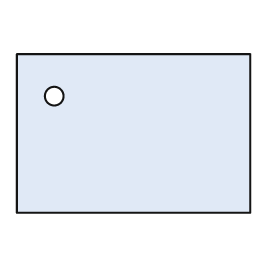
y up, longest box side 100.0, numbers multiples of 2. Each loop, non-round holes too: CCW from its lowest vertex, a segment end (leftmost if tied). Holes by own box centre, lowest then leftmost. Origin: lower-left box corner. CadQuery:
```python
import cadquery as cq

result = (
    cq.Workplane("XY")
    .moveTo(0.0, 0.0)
    .lineTo(100.0, 0.0)
    .lineTo(100.0, 68.0)
    .lineTo(0.0, 68.0)
    .close()
    .moveTo(16.0, 50.0)
    .circle(4.0)
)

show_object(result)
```